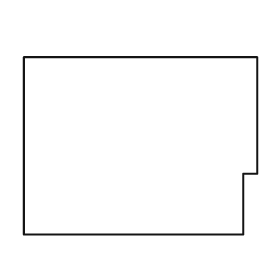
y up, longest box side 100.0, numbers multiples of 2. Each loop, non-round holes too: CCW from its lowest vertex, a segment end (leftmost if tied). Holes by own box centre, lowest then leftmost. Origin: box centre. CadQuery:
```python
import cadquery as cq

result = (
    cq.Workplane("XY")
    .moveTo(-50.0, -38.0)
    .lineTo(44.0, -38.0)
    .lineTo(44.0, -12.0)
    .lineTo(50.0, -12.0)
    .lineTo(50.0, 38.0)
    .lineTo(-50.0, 38.0)
    .close()
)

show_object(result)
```